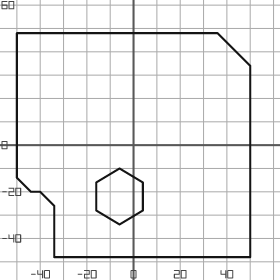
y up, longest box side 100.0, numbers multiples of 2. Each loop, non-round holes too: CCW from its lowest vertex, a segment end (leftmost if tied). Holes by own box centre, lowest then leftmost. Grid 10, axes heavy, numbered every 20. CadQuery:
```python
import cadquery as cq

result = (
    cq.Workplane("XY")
    .moveTo(-34.0, -48.0)
    .lineTo(50.0, -48.0)
    .lineTo(50.0, 34.0)
    .lineTo(36.0, 48.0)
    .lineTo(-50.0, 48.0)
    .lineTo(-50.0, -14.0)
    .lineTo(-44.0, -20.0)
    .lineTo(-40.0, -20.0)
    .lineTo(-34.0, -26.0)
    .close()
    .moveTo(-6.0, -34.0)
    .lineTo(4.0, -28.0)
    .lineTo(4.0, -16.0)
    .lineTo(-6.0, -10.0)
    .lineTo(-16.0, -16.0)
    .lineTo(-16.0, -28.0)
    .close()
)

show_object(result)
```